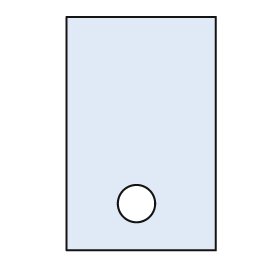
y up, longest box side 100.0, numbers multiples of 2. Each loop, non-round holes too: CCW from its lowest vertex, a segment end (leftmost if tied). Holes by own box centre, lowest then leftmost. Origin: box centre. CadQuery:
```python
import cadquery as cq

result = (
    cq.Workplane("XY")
    .moveTo(-32.0, -50.0)
    .lineTo(32.0, -50.0)
    .lineTo(32.0, 50.0)
    .lineTo(-32.0, 50.0)
    .close()
    .moveTo(-2.0, -30.0)
    .circle(8.0)
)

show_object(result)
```